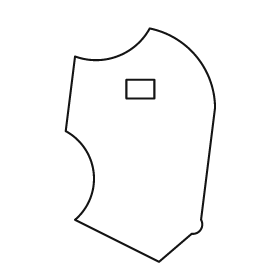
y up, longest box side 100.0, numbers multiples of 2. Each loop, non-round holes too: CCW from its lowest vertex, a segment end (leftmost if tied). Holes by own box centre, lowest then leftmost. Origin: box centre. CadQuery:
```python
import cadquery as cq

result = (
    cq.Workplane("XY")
    .moveTo(8.0, -50.0)
    .lineTo(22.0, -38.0)
    .threePointArc((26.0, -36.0), (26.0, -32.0))
    .lineTo(32.0, 16.0)
    .threePointArc((24.0, 38.0), (4.0, 50.0))
    .threePointArc((-10.0, 38.0), (-28.0, 38.0))
    .lineTo(-32.0, 6.0)
    .threePointArc((-20.0, -12.0), (-28.0, -32.0))
    .close()
    .moveTo(-6.0, 20.0)
    .lineTo(6.0, 20.0)
    .lineTo(6.0, 28.0)
    .lineTo(-6.0, 28.0)
    .close()
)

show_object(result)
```